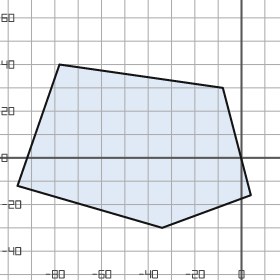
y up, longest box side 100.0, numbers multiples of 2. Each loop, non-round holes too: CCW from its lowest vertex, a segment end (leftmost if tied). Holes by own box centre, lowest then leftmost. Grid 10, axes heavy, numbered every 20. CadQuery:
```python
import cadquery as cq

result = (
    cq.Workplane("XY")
    .moveTo(-34.0, -30.0)
    .lineTo(4.0, -16.0)
    .lineTo(-8.0, 30.0)
    .lineTo(-78.0, 40.0)
    .lineTo(-96.0, -12.0)
    .close()
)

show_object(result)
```